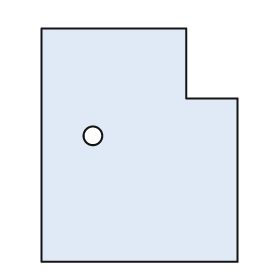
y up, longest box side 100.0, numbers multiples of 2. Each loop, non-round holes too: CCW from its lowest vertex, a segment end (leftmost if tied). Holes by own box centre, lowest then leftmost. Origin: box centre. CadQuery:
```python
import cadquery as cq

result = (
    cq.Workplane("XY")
    .moveTo(-42.0, -50.0)
    .lineTo(42.0, -50.0)
    .lineTo(42.0, 20.0)
    .lineTo(20.0, 20.0)
    .lineTo(20.0, 50.0)
    .lineTo(-42.0, 50.0)
    .close()
    .moveTo(-20.0, 4.0)
    .circle(4.0)
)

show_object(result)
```